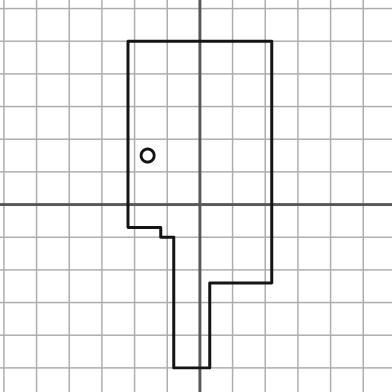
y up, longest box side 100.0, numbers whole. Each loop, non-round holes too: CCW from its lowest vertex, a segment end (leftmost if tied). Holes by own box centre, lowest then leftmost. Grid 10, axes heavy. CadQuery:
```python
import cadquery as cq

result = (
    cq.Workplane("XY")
    .moveTo(-8.0, -50.0)
    .lineTo(3.0, -50.0)
    .lineTo(3.0, -24.0)
    .lineTo(22.0, -24.0)
    .lineTo(22.0, 50.0)
    .lineTo(-22.0, 50.0)
    .lineTo(-22.0, -7.0)
    .lineTo(-12.0, -7.0)
    .lineTo(-12.0, -10.0)
    .lineTo(-8.0, -10.0)
    .close()
    .moveTo(-16.0, 15.0)
    .circle(2.0)
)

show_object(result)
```